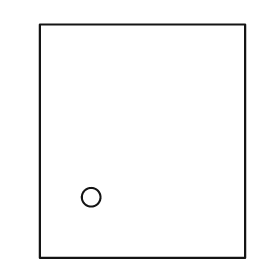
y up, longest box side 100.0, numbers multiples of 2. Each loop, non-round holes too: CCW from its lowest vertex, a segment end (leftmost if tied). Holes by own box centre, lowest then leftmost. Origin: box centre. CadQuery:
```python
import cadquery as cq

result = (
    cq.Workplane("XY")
    .moveTo(-44.0, -50.0)
    .lineTo(44.0, -50.0)
    .lineTo(44.0, 50.0)
    .lineTo(-44.0, 50.0)
    .close()
    .moveTo(-22.0, -24.0)
    .circle(4.0)
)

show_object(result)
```